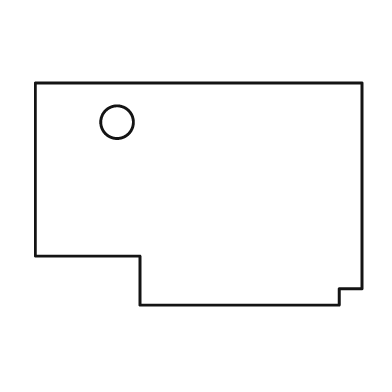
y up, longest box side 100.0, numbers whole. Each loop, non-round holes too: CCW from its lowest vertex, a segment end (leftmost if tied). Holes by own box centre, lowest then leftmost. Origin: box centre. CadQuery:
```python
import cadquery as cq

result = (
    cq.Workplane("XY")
    .moveTo(-18.0, -34.0)
    .lineTo(43.0, -34.0)
    .lineTo(43.0, -29.0)
    .lineTo(50.0, -29.0)
    .lineTo(50.0, 34.0)
    .lineTo(-50.0, 34.0)
    .lineTo(-50.0, -19.0)
    .lineTo(-18.0, -19.0)
    .close()
    .moveTo(-25.0, 22.0)
    .circle(5.0)
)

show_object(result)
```